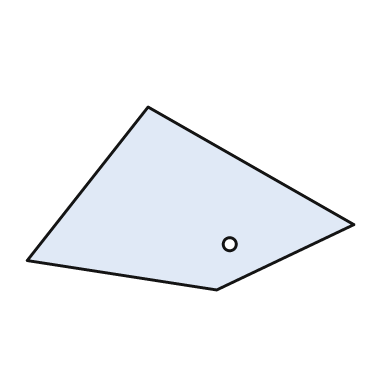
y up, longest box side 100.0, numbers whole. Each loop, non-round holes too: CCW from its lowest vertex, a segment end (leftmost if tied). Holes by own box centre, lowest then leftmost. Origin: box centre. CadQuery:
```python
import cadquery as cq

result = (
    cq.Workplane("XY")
    .moveTo(8.0, -28.0)
    .lineTo(50.0, -8.0)
    .lineTo(-13.0, 28.0)
    .lineTo(-50.0, -19.0)
    .close()
    .moveTo(12.0, -14.0)
    .circle(2.0)
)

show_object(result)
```